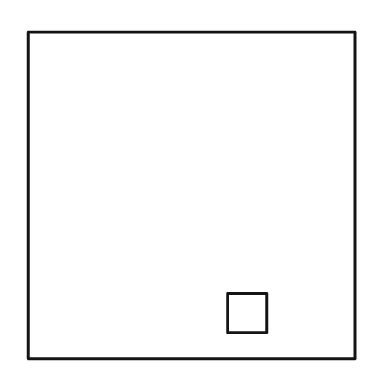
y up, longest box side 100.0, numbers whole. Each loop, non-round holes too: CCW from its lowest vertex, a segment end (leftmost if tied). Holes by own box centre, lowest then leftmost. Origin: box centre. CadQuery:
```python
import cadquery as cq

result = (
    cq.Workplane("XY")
    .moveTo(-50.0, -50.0)
    .lineTo(50.0, -50.0)
    .lineTo(50.0, 50.0)
    .lineTo(-50.0, 50.0)
    .close()
    .moveTo(11.0, -42.0)
    .lineTo(23.0, -42.0)
    .lineTo(23.0, -30.0)
    .lineTo(11.0, -30.0)
    .close()
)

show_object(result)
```